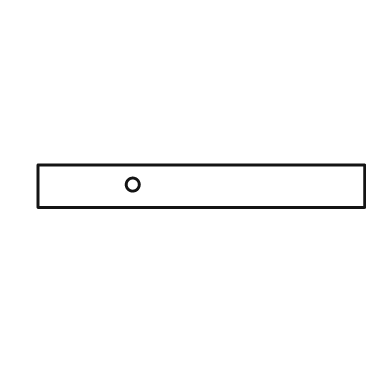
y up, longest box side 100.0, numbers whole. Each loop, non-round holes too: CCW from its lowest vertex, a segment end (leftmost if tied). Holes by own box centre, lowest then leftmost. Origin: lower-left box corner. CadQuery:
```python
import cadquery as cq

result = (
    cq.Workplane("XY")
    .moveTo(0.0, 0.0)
    .lineTo(100.0, 0.0)
    .lineTo(100.0, 13.0)
    .lineTo(0.0, 13.0)
    .close()
    .moveTo(29.0, 7.0)
    .circle(2.0)
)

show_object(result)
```